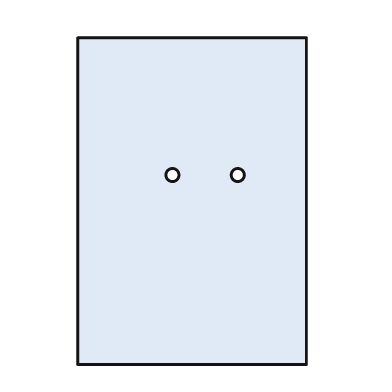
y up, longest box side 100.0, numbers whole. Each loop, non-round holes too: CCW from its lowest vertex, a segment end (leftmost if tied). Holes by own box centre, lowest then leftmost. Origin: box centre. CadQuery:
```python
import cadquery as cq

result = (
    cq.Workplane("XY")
    .moveTo(-35.0, -50.0)
    .lineTo(35.0, -50.0)
    .lineTo(35.0, 50.0)
    .lineTo(-35.0, 50.0)
    .close()
    .moveTo(-6.0, 8.0)
    .circle(2.0)
    .moveTo(14.0, 8.0)
    .circle(2.0)
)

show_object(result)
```